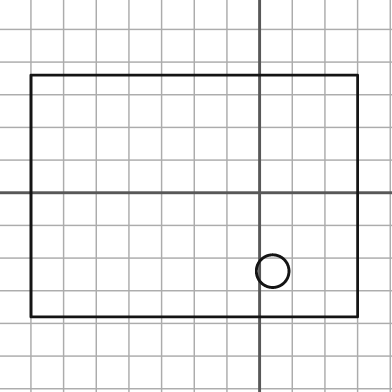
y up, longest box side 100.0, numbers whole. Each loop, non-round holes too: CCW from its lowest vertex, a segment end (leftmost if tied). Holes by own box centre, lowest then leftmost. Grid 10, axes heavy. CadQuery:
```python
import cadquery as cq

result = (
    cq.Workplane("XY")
    .moveTo(-70.0, -38.0)
    .lineTo(30.0, -38.0)
    .lineTo(30.0, 36.0)
    .lineTo(-70.0, 36.0)
    .close()
    .moveTo(4.0, -24.0)
    .circle(5.0)
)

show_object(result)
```